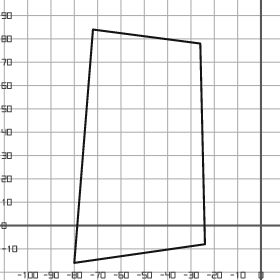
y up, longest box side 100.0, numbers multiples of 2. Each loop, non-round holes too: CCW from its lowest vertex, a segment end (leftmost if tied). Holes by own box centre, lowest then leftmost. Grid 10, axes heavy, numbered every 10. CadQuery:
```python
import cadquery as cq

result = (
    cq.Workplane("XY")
    .moveTo(-80.0, -16.0)
    .lineTo(-24.0, -8.0)
    .lineTo(-26.0, 78.0)
    .lineTo(-72.0, 84.0)
    .close()
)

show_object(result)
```